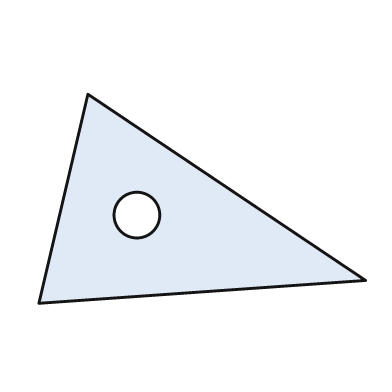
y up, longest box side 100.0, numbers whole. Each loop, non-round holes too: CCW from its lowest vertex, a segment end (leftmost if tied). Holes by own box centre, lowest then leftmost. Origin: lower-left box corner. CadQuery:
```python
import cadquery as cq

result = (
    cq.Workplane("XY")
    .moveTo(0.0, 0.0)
    .lineTo(100.0, 7.0)
    .lineTo(15.0, 64.0)
    .close()
    .moveTo(30.0, 27.0)
    .circle(7.0)
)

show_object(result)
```